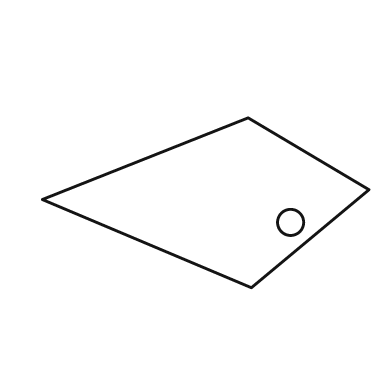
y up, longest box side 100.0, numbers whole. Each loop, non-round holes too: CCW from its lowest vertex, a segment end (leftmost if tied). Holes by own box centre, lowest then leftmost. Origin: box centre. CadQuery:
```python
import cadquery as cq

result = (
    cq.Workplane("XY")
    .moveTo(14.0, -26.0)
    .lineTo(50.0, 4.0)
    .lineTo(13.0, 26.0)
    .lineTo(-50.0, 1.0)
    .close()
    .moveTo(26.0, -6.0)
    .circle(4.0)
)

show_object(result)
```